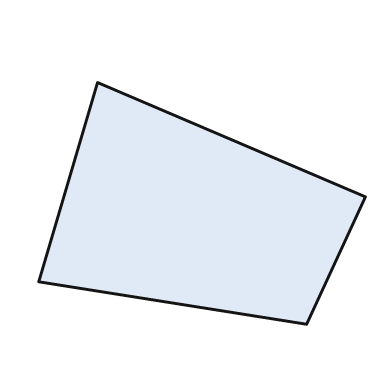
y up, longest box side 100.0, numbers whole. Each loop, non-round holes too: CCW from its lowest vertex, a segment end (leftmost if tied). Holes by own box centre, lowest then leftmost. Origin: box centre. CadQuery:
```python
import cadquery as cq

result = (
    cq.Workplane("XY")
    .moveTo(32.0, -37.0)
    .lineTo(50.0, 2.0)
    .lineTo(-32.0, 37.0)
    .lineTo(-50.0, -24.0)
    .close()
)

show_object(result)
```